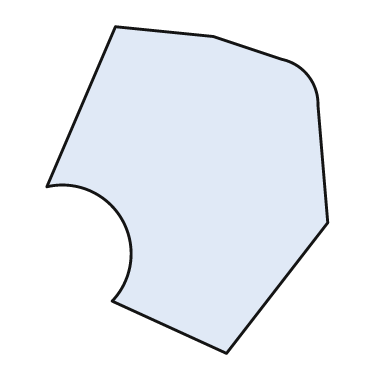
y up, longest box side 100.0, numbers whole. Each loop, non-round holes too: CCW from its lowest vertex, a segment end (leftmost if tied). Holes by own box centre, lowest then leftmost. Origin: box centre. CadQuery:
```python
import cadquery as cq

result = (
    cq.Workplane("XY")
    .moveTo(12.0, -50.0)
    .lineTo(43.0, -10.0)
    .lineTo(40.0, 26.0)
    .threePointArc((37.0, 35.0), (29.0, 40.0))
    .lineTo(8.0, 47.0)
    .lineTo(-22.0, 50.0)
    .lineTo(-43.0, 1.0)
    .threePointArc((-20.0, -9.0), (-23.0, -34.0))
    .close()
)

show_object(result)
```